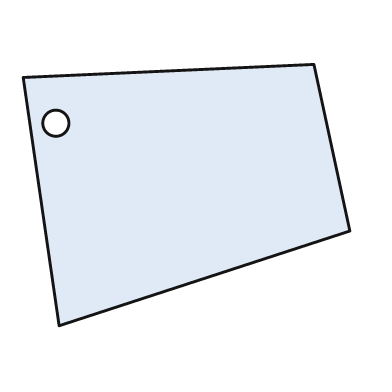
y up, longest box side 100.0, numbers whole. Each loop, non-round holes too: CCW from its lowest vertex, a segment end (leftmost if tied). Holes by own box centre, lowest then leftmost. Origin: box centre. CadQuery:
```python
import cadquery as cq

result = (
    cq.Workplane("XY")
    .moveTo(-39.0, -40.0)
    .lineTo(50.0, -11.0)
    .lineTo(39.0, 40.0)
    .lineTo(-50.0, 36.0)
    .close()
    .moveTo(-40.0, 22.0)
    .circle(4.0)
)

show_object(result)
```